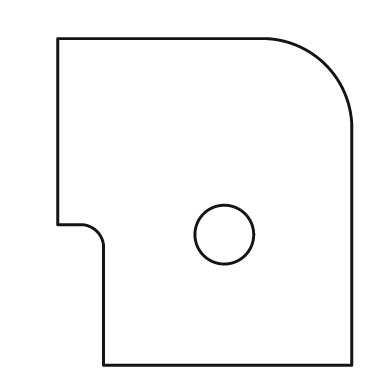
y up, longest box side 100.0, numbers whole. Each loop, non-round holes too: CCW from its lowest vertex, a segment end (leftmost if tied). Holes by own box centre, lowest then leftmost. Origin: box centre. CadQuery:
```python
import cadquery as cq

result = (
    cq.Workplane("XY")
    .moveTo(-31.0, -50.0)
    .lineTo(45.0, -50.0)
    .lineTo(45.0, 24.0)
    .threePointArc((37.0, 42.0), (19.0, 50.0))
    .lineTo(-45.0, 50.0)
    .lineTo(-45.0, -7.0)
    .lineTo(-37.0, -7.0)
    .threePointArc((-33.0, -9.0), (-31.0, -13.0))
    .close()
    .moveTo(6.0, -10.0)
    .circle(9.0)
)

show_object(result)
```